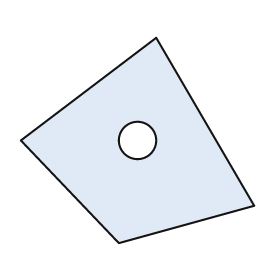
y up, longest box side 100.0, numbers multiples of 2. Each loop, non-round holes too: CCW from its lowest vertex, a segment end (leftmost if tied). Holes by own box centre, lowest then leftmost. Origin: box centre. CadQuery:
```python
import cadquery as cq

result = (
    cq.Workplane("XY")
    .moveTo(-8.0, -44.0)
    .lineTo(50.0, -28.0)
    .lineTo(8.0, 44.0)
    .lineTo(-50.0, 0.0)
    .close()
    .moveTo(0.0, 0.0)
    .circle(8.0)
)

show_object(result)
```